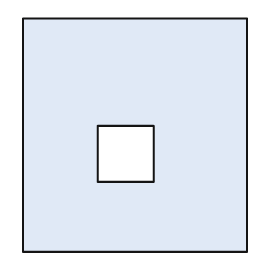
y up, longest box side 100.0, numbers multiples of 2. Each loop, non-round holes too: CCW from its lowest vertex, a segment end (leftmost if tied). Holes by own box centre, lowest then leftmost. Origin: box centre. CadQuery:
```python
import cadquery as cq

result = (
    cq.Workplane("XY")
    .moveTo(-48.0, -50.0)
    .lineTo(48.0, -50.0)
    .lineTo(48.0, 50.0)
    .lineTo(-48.0, 50.0)
    .close()
    .moveTo(-16.0, -20.0)
    .lineTo(8.0, -20.0)
    .lineTo(8.0, 4.0)
    .lineTo(-16.0, 4.0)
    .close()
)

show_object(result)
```